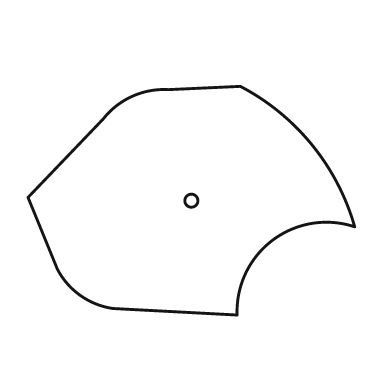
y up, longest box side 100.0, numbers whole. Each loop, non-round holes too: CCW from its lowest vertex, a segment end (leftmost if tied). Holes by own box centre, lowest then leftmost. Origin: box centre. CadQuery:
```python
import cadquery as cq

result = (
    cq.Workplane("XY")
    .moveTo(14.0, -35.0)
    .threePointArc((25.0, -12.0), (50.0, -8.0))
    .threePointArc((37.0, 17.0), (15.0, 35.0))
    .lineTo(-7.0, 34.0)
    .threePointArc((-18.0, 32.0), (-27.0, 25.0))
    .lineTo(-50.0, 1.0)
    .lineTo(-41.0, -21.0)
    .threePointArc((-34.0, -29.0), (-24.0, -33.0))
    .close()
    .moveTo(0.0, 0.0)
    .circle(2.0)
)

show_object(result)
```